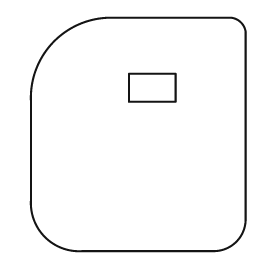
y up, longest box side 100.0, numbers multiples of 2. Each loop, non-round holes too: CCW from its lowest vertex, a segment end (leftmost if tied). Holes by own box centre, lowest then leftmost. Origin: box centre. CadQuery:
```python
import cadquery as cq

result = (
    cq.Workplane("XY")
    .moveTo(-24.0, -50.0)
    .lineTo(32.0, -50.0)
    .threePointArc((42.0, -46.0), (46.0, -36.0))
    .lineTo(46.0, 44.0)
    .threePointArc((44.0, 48.0), (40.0, 50.0))
    .lineTo(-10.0, 50.0)
    .threePointArc((-36.0, 40.0), (-46.0, 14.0))
    .lineTo(-46.0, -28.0)
    .threePointArc((-40.0, -44.0), (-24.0, -50.0))
    .close()
    .moveTo(-4.0, 14.0)
    .lineTo(16.0, 14.0)
    .lineTo(16.0, 26.0)
    .lineTo(-4.0, 26.0)
    .close()
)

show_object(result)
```